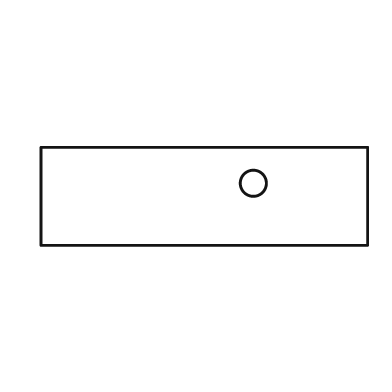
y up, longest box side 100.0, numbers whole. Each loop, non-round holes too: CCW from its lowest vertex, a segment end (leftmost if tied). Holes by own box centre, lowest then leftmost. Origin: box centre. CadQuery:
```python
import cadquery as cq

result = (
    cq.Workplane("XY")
    .moveTo(-50.0, -15.0)
    .lineTo(50.0, -15.0)
    .lineTo(50.0, 15.0)
    .lineTo(-50.0, 15.0)
    .close()
    .moveTo(15.0, 4.0)
    .circle(4.0)
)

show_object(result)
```